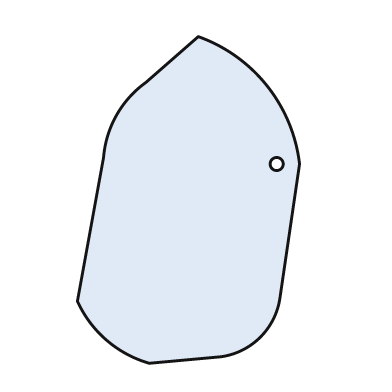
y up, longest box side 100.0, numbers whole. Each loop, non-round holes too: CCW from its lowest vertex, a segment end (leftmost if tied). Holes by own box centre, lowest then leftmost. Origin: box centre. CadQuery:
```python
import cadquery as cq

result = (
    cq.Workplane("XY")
    .moveTo(-12.0, -50.0)
    .lineTo(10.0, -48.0)
    .threePointArc((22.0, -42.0), (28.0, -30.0))
    .lineTo(34.0, 11.0)
    .threePointArc((24.0, 35.0), (3.0, 50.0))
    .lineTo(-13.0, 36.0)
    .threePointArc((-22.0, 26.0), (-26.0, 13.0))
    .lineTo(-34.0, -31.0)
    .threePointArc((-25.0, -43.0), (-12.0, -50.0))
    .close()
    .moveTo(27.0, 11.0)
    .circle(2.0)
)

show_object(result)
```